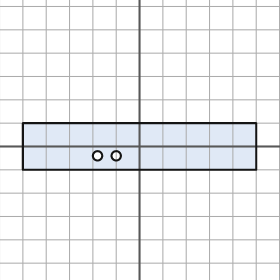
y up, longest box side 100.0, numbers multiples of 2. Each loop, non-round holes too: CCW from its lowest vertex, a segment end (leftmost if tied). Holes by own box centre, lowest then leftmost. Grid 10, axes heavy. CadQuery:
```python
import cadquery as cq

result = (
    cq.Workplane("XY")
    .moveTo(-50.0, -10.0)
    .lineTo(50.0, -10.0)
    .lineTo(50.0, 10.0)
    .lineTo(-50.0, 10.0)
    .close()
    .moveTo(-18.0, -4.0)
    .circle(2.0)
    .moveTo(-10.0, -4.0)
    .circle(2.0)
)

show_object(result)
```